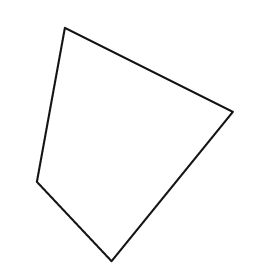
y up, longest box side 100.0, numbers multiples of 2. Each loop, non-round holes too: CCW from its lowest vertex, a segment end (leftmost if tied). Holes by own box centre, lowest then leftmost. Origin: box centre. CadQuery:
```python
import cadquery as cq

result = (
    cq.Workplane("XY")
    .moveTo(-10.0, -50.0)
    .lineTo(42.0, 14.0)
    .lineTo(-30.0, 50.0)
    .lineTo(-42.0, -16.0)
    .close()
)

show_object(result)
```